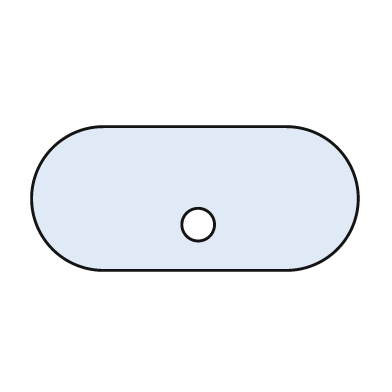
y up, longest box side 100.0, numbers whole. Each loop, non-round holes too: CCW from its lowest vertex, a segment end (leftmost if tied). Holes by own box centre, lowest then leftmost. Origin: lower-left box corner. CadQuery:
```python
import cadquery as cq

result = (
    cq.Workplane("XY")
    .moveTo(22.0, 0.0)
    .lineTo(78.0, 0.0)
    .threePointArc((100.0, 22.0), (78.0, 44.0))
    .lineTo(22.0, 44.0)
    .threePointArc((0.0, 22.0), (22.0, 0.0))
    .close()
    .moveTo(51.0, 14.0)
    .circle(5.0)
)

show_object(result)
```